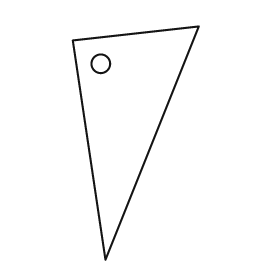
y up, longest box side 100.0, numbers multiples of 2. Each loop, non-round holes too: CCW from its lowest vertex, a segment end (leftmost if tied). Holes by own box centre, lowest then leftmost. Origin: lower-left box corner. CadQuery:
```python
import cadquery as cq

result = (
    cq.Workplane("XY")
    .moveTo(14.0, 0.0)
    .lineTo(54.0, 100.0)
    .lineTo(0.0, 94.0)
    .close()
    .moveTo(12.0, 84.0)
    .circle(4.0)
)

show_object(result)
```